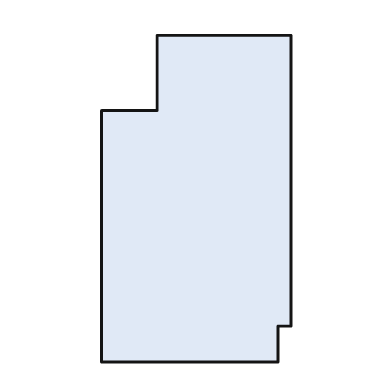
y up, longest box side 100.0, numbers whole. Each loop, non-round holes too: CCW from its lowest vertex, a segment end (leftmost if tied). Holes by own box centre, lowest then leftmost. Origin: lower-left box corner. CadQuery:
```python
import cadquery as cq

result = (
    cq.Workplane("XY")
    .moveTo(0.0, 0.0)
    .lineTo(54.0, 0.0)
    .lineTo(54.0, 11.0)
    .lineTo(58.0, 11.0)
    .lineTo(58.0, 100.0)
    .lineTo(17.0, 100.0)
    .lineTo(17.0, 77.0)
    .lineTo(0.0, 77.0)
    .close()
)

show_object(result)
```